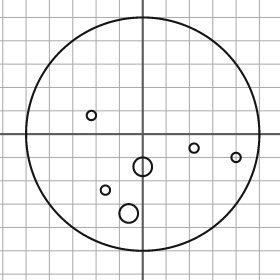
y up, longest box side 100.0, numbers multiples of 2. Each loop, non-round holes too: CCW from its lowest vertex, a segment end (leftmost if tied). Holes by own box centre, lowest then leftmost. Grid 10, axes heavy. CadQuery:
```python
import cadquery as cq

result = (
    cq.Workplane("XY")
    .moveTo(0.0, 0.0)
    .circle(50.0)
    .moveTo(-6.0, -34.0)
    .circle(4.0)
    .moveTo(-16.0, -24.0)
    .circle(2.0)
    .moveTo(0.0, -14.0)
    .circle(4.0)
    .moveTo(40.0, -10.0)
    .circle(2.0)
    .moveTo(22.0, -6.0)
    .circle(2.0)
    .moveTo(-22.0, 8.0)
    .circle(2.0)
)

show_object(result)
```